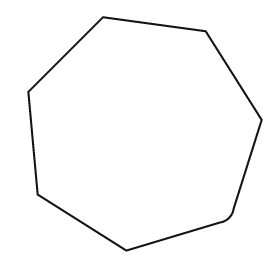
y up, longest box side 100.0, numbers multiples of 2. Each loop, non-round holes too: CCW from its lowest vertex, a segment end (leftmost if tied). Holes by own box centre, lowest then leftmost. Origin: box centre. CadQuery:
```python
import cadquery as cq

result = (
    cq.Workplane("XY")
    .moveTo(-8.0, -50.0)
    .lineTo(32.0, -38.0)
    .threePointArc((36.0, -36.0), (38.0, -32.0))
    .lineTo(50.0, 6.0)
    .lineTo(26.0, 44.0)
    .lineTo(-18.0, 50.0)
    .lineTo(-50.0, 18.0)
    .lineTo(-46.0, -26.0)
    .close()
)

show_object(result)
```